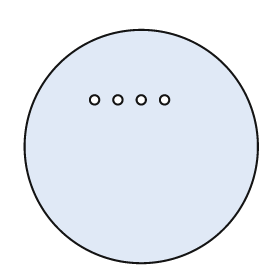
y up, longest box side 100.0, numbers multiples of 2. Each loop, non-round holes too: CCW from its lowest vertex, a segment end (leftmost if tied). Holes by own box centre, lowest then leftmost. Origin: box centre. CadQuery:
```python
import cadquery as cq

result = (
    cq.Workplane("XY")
    .moveTo(0.0, 0.0)
    .circle(50.0)
    .moveTo(-20.0, 20.0)
    .circle(2.0)
    .moveTo(-10.0, 20.0)
    .circle(2.0)
    .moveTo(0.0, 20.0)
    .circle(2.0)
    .moveTo(10.0, 20.0)
    .circle(2.0)
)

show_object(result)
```